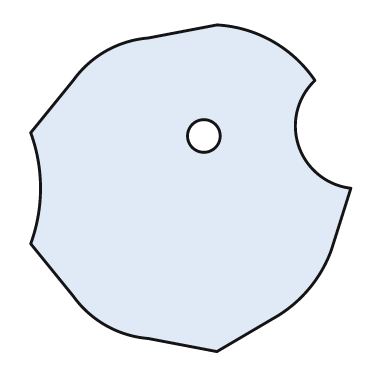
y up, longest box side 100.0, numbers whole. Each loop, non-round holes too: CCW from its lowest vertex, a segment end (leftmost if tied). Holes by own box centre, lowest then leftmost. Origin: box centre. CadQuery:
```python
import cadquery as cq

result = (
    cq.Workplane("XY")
    .moveTo(8.0, -50.0)
    .lineTo(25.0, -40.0)
    .threePointArc((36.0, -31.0), (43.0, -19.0))
    .lineTo(49.0, 0.0)
    .threePointArc((33.0, 13.0), (38.0, 33.0))
    .threePointArc((25.0, 45.0), (8.0, 50.0))
    .lineTo(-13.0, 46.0)
    .threePointArc((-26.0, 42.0), (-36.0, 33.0))
    .lineTo(-49.0, 17.0)
    .threePointArc((-46.0, 0.0), (-49.0, -17.0))
    .lineTo(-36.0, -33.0)
    .threePointArc((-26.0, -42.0), (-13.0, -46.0))
    .close()
    .moveTo(4.0, 16.0)
    .circle(5.0)
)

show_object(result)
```